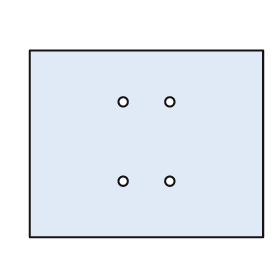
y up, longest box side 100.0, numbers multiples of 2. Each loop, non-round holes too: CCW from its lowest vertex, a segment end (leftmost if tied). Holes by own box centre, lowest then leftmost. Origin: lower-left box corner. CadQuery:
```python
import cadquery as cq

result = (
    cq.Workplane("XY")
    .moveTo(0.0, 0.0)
    .lineTo(100.0, 0.0)
    .lineTo(100.0, 80.0)
    .lineTo(0.0, 80.0)
    .close()
    .moveTo(40.0, 24.0)
    .circle(2.0)
    .moveTo(60.0, 24.0)
    .circle(2.0)
    .moveTo(40.0, 58.0)
    .circle(2.0)
    .moveTo(60.0, 58.0)
    .circle(2.0)
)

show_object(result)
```